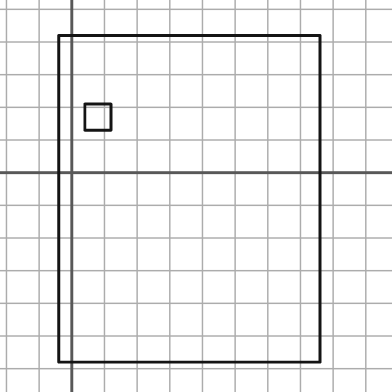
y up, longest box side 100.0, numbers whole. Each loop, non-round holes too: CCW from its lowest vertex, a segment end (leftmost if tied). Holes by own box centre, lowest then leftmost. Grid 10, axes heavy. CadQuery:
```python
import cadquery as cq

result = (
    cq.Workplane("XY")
    .moveTo(-4.0, -58.0)
    .lineTo(76.0, -58.0)
    .lineTo(76.0, 42.0)
    .lineTo(-4.0, 42.0)
    .close()
    .moveTo(4.0, 13.0)
    .lineTo(12.0, 13.0)
    .lineTo(12.0, 21.0)
    .lineTo(4.0, 21.0)
    .close()
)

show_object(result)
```